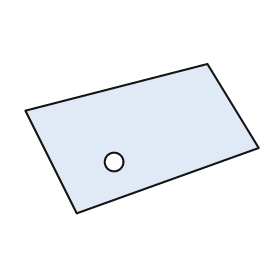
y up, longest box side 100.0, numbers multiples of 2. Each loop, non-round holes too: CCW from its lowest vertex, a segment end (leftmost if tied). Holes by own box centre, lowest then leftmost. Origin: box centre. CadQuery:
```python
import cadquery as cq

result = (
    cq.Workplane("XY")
    .moveTo(-28.0, -32.0)
    .lineTo(50.0, -4.0)
    .lineTo(28.0, 32.0)
    .lineTo(-50.0, 12.0)
    .close()
    .moveTo(-12.0, -10.0)
    .circle(4.0)
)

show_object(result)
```